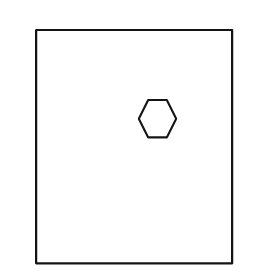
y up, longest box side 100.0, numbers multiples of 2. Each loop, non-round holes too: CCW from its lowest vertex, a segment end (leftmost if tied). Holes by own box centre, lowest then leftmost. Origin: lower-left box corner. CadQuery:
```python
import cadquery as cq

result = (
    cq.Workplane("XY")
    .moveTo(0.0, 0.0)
    .lineTo(84.0, 0.0)
    .lineTo(84.0, 100.0)
    .lineTo(0.0, 100.0)
    .close()
    .moveTo(48.0, 54.0)
    .lineTo(56.0, 54.0)
    .lineTo(60.0, 62.0)
    .lineTo(56.0, 70.0)
    .lineTo(48.0, 70.0)
    .lineTo(44.0, 62.0)
    .close()
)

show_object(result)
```